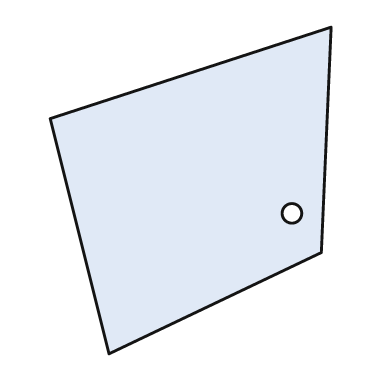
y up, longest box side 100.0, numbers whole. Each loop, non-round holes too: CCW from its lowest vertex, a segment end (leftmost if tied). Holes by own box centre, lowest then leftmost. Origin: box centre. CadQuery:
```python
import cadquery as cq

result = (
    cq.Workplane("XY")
    .moveTo(-25.0, -50.0)
    .lineTo(40.0, -19.0)
    .lineTo(43.0, 50.0)
    .lineTo(-43.0, 22.0)
    .close()
    .moveTo(31.0, -7.0)
    .circle(3.0)
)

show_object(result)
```